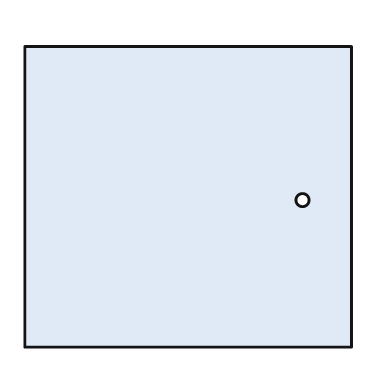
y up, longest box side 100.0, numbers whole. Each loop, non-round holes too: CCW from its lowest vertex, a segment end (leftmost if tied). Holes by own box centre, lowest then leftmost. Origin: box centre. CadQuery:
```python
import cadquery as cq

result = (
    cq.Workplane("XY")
    .moveTo(-50.0, -46.0)
    .lineTo(50.0, -46.0)
    .lineTo(50.0, 46.0)
    .lineTo(-50.0, 46.0)
    .close()
    .moveTo(35.0, -1.0)
    .circle(2.0)
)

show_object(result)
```